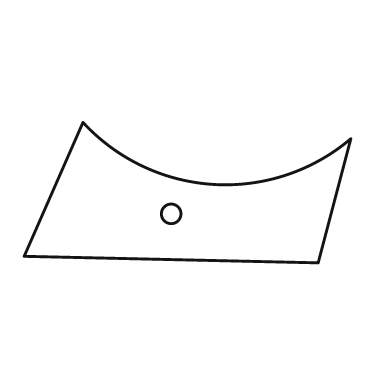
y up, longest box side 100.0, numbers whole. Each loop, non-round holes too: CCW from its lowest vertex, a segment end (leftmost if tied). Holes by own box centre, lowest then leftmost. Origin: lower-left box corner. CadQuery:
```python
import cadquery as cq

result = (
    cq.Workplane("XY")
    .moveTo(90.0, 0.0)
    .lineTo(100.0, 38.0)
    .threePointArc((58.0, 24.0), (18.0, 43.0))
    .lineTo(0.0, 2.0)
    .close()
    .moveTo(45.0, 15.0)
    .circle(3.0)
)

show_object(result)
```